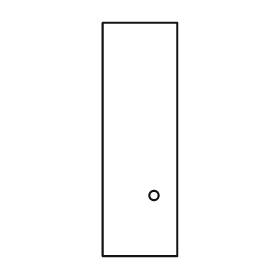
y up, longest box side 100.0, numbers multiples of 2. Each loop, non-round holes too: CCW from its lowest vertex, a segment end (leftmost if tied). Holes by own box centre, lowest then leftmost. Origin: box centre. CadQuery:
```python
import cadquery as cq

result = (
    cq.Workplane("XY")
    .moveTo(-16.0, -50.0)
    .lineTo(16.0, -50.0)
    .lineTo(16.0, 50.0)
    .lineTo(-16.0, 50.0)
    .close()
    .moveTo(6.0, -24.0)
    .circle(2.0)
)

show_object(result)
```